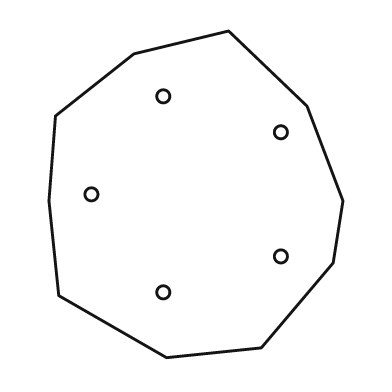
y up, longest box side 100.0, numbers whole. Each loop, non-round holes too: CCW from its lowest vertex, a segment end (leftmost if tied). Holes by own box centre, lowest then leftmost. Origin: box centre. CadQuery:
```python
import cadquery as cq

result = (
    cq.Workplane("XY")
    .moveTo(-9.0, -50.0)
    .lineTo(20.0, -47.0)
    .lineTo(42.0, -21.0)
    .lineTo(45.0, -2.0)
    .lineTo(34.0, 27.0)
    .lineTo(10.0, 50.0)
    .lineTo(-19.0, 43.0)
    .lineTo(-43.0, 24.0)
    .lineTo(-45.0, -2.0)
    .lineTo(-42.0, -31.0)
    .close()
    .moveTo(-10.0, -30.0)
    .circle(2.0)
    .moveTo(26.0, -19.0)
    .circle(2.0)
    .moveTo(-32.0, 0.0)
    .circle(2.0)
    .moveTo(26.0, 19.0)
    .circle(2.0)
    .moveTo(-10.0, 30.0)
    .circle(2.0)
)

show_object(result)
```